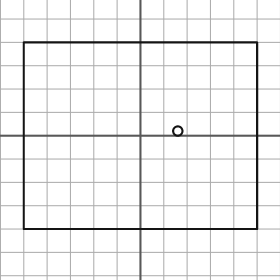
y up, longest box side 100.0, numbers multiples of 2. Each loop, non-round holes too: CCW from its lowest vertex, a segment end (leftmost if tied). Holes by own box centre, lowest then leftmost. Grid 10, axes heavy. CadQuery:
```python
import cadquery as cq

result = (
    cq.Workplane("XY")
    .moveTo(-50.0, -40.0)
    .lineTo(50.0, -40.0)
    .lineTo(50.0, 40.0)
    .lineTo(-50.0, 40.0)
    .close()
    .moveTo(16.0, 2.0)
    .circle(2.0)
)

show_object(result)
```